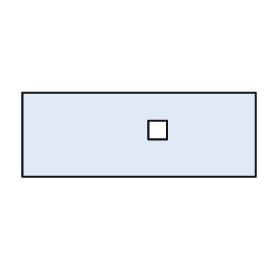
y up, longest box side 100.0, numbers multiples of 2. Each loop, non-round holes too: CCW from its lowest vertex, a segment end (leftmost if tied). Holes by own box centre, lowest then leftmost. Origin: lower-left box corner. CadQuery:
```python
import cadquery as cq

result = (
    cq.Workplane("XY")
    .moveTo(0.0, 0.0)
    .lineTo(100.0, 0.0)
    .lineTo(100.0, 36.0)
    .lineTo(0.0, 36.0)
    .close()
    .moveTo(54.0, 16.0)
    .lineTo(62.0, 16.0)
    .lineTo(62.0, 24.0)
    .lineTo(54.0, 24.0)
    .close()
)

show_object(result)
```